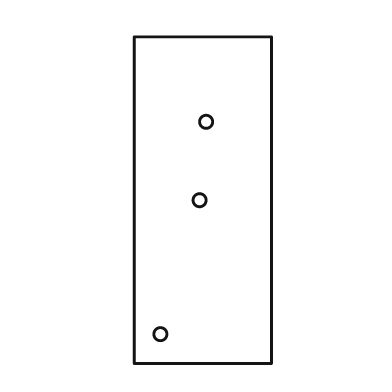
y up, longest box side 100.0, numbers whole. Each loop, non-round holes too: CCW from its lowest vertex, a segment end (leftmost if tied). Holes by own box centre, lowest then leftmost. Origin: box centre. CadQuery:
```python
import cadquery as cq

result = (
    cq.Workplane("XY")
    .moveTo(-21.0, -50.0)
    .lineTo(21.0, -50.0)
    .lineTo(21.0, 50.0)
    .lineTo(-21.0, 50.0)
    .close()
    .moveTo(-13.0, -41.0)
    .circle(2.0)
    .moveTo(-1.0, 0.0)
    .circle(2.0)
    .moveTo(1.0, 24.0)
    .circle(2.0)
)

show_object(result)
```